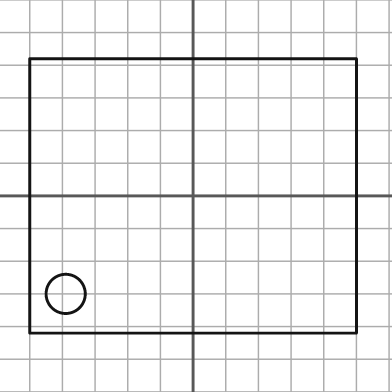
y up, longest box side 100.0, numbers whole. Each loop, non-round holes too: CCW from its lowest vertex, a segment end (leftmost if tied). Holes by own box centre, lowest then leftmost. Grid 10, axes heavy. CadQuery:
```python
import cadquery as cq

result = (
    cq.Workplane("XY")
    .moveTo(-50.0, -42.0)
    .lineTo(50.0, -42.0)
    .lineTo(50.0, 42.0)
    .lineTo(-50.0, 42.0)
    .close()
    .moveTo(-39.0, -30.0)
    .circle(6.0)
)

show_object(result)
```